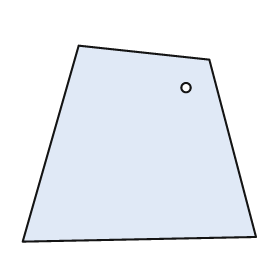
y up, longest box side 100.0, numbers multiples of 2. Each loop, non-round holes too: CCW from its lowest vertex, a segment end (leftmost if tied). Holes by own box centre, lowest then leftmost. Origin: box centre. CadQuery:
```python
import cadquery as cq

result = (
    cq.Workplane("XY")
    .moveTo(-50.0, -42.0)
    .lineTo(50.0, -40.0)
    .lineTo(30.0, 36.0)
    .lineTo(-26.0, 42.0)
    .close()
    .moveTo(20.0, 24.0)
    .circle(2.0)
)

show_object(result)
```